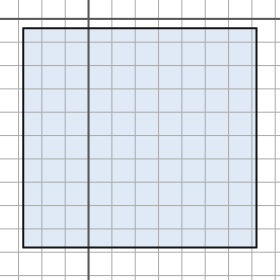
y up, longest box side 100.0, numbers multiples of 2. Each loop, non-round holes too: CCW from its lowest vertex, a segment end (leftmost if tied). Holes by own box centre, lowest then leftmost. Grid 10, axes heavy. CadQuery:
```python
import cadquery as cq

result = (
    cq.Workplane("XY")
    .moveTo(-28.0, -98.0)
    .lineTo(72.0, -98.0)
    .lineTo(72.0, -4.0)
    .lineTo(-28.0, -4.0)
    .close()
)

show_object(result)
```